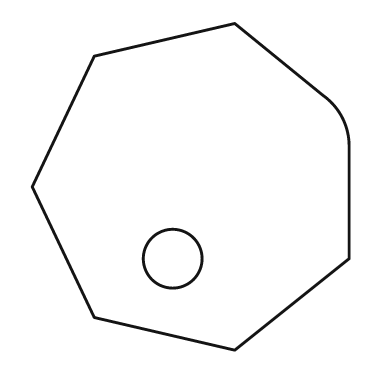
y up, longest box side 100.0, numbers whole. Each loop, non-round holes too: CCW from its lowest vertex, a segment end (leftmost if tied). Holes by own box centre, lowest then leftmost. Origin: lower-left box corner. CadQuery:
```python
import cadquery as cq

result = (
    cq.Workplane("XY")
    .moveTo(62.0, 0.0)
    .lineTo(97.0, 28.0)
    .lineTo(97.0, 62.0)
    .threePointArc((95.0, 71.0), (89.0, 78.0))
    .lineTo(62.0, 100.0)
    .lineTo(19.0, 90.0)
    .lineTo(0.0, 50.0)
    .lineTo(19.0, 10.0)
    .close()
    .moveTo(43.0, 28.0)
    .circle(9.0)
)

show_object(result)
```